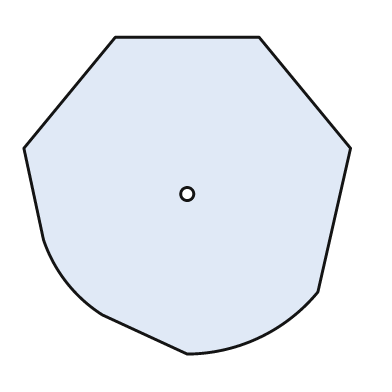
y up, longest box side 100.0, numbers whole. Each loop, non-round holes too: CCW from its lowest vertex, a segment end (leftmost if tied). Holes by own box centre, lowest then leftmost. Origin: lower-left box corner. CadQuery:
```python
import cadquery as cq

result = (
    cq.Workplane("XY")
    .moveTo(50.0, 0.0)
    .threePointArc((72.0, 5.0), (90.0, 19.0))
    .lineTo(100.0, 63.0)
    .lineTo(72.0, 97.0)
    .lineTo(28.0, 97.0)
    .lineTo(0.0, 63.0)
    .lineTo(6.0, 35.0)
    .threePointArc((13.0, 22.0), (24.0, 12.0))
    .close()
    .moveTo(50.0, 49.0)
    .circle(2.0)
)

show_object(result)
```